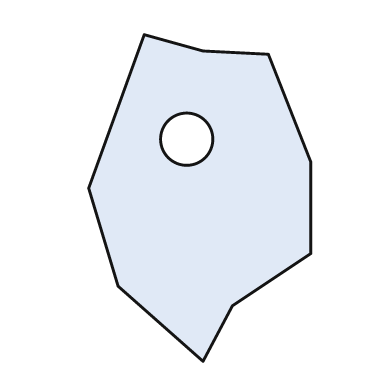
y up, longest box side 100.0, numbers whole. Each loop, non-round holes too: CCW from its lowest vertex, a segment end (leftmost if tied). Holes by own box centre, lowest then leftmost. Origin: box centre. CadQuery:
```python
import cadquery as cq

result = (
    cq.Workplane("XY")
    .moveTo(1.0, -50.0)
    .lineTo(10.0, -33.0)
    .lineTo(34.0, -17.0)
    .lineTo(34.0, 11.0)
    .lineTo(21.0, 44.0)
    .lineTo(1.0, 45.0)
    .lineTo(-17.0, 50.0)
    .lineTo(-34.0, 3.0)
    .lineTo(-25.0, -27.0)
    .close()
    .moveTo(-4.0, 18.0)
    .circle(8.0)
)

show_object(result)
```